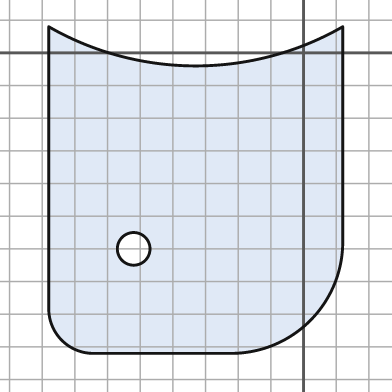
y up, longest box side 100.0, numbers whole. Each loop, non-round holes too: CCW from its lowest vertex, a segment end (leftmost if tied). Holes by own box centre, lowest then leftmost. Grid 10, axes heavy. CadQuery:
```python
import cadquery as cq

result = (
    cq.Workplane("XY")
    .moveTo(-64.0, -92.0)
    .lineTo(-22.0, -92.0)
    .threePointArc((2.0, -82.0), (12.0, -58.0))
    .lineTo(12.0, 8.0)
    .threePointArc((-33.0, -4.0), (-78.0, 8.0))
    .lineTo(-78.0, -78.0)
    .threePointArc((-74.0, -88.0), (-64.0, -92.0))
    .close()
    .moveTo(-52.0, -60.0)
    .circle(5.0)
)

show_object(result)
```